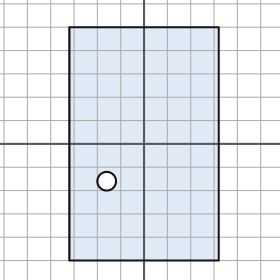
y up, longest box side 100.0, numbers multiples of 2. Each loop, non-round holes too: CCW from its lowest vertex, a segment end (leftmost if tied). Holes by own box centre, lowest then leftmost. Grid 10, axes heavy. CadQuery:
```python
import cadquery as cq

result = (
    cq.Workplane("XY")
    .moveTo(-32.0, -50.0)
    .lineTo(32.0, -50.0)
    .lineTo(32.0, 50.0)
    .lineTo(-32.0, 50.0)
    .close()
    .moveTo(-16.0, -16.0)
    .circle(4.0)
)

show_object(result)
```